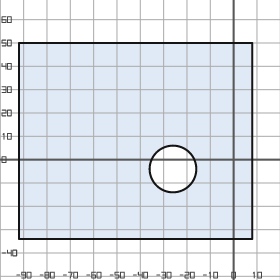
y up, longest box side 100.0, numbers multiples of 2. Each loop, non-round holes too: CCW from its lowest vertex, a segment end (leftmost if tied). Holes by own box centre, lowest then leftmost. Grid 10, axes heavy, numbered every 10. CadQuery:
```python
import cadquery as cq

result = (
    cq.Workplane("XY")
    .moveTo(-92.0, -34.0)
    .lineTo(8.0, -34.0)
    .lineTo(8.0, 50.0)
    .lineTo(-92.0, 50.0)
    .close()
    .moveTo(-26.0, -4.0)
    .circle(10.0)
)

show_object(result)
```